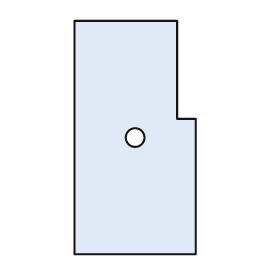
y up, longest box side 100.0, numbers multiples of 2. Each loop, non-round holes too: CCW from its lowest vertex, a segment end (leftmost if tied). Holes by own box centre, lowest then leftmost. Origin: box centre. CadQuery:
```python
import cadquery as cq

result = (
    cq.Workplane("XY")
    .moveTo(-26.0, -50.0)
    .lineTo(26.0, -50.0)
    .lineTo(26.0, 8.0)
    .lineTo(18.0, 8.0)
    .lineTo(18.0, 50.0)
    .lineTo(-26.0, 50.0)
    .close()
    .moveTo(0.0, 0.0)
    .circle(4.0)
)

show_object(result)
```